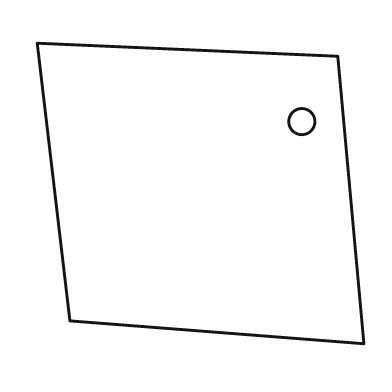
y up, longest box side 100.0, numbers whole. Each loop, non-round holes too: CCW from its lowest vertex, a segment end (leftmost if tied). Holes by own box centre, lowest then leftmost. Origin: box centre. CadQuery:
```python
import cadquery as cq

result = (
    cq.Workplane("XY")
    .moveTo(50.0, -46.0)
    .lineTo(42.0, 42.0)
    .lineTo(-50.0, 46.0)
    .lineTo(-40.0, -39.0)
    .close()
    .moveTo(31.0, 22.0)
    .circle(4.0)
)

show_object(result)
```